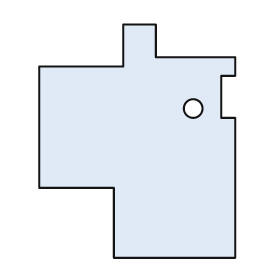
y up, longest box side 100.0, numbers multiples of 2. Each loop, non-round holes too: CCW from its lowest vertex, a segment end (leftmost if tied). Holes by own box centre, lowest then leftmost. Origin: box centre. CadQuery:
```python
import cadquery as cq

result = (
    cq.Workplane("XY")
    .moveTo(-10.0, -50.0)
    .lineTo(42.0, -50.0)
    .lineTo(42.0, 10.0)
    .lineTo(36.0, 10.0)
    .lineTo(36.0, 28.0)
    .lineTo(42.0, 28.0)
    .lineTo(42.0, 36.0)
    .lineTo(8.0, 36.0)
    .lineTo(8.0, 50.0)
    .lineTo(-6.0, 50.0)
    .lineTo(-6.0, 32.0)
    .lineTo(-42.0, 32.0)
    .lineTo(-42.0, -20.0)
    .lineTo(-10.0, -20.0)
    .close()
    .moveTo(24.0, 14.0)
    .circle(4.0)
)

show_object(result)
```